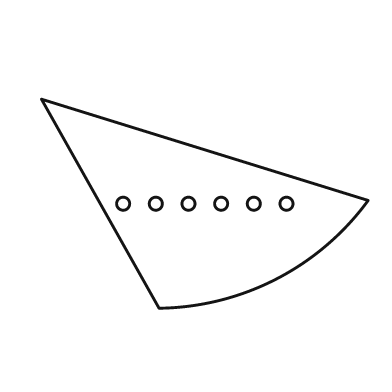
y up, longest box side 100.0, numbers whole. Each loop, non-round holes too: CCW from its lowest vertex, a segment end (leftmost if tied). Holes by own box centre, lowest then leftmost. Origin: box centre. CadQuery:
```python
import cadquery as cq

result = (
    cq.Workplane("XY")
    .moveTo(-14.0, -32.0)
    .threePointArc((22.0, -23.0), (50.0, 1.0))
    .lineTo(-50.0, 32.0)
    .close()
    .moveTo(-25.0, 0.0)
    .circle(2.0)
    .moveTo(-15.0, 0.0)
    .circle(2.0)
    .moveTo(-5.0, 0.0)
    .circle(2.0)
    .moveTo(5.0, 0.0)
    .circle(2.0)
    .moveTo(15.0, 0.0)
    .circle(2.0)
    .moveTo(25.0, 0.0)
    .circle(2.0)
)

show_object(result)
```